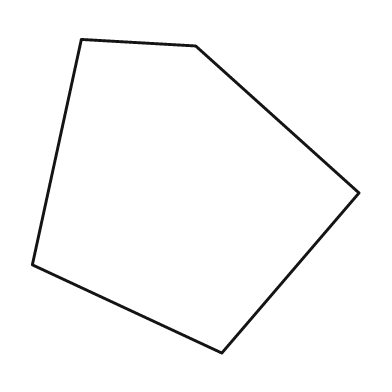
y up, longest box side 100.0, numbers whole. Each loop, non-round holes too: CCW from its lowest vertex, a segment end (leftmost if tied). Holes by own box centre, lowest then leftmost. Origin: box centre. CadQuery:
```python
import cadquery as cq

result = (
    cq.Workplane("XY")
    .moveTo(8.0, -48.0)
    .lineTo(50.0, 1.0)
    .lineTo(0.0, 46.0)
    .lineTo(-35.0, 48.0)
    .lineTo(-50.0, -21.0)
    .close()
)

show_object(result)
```